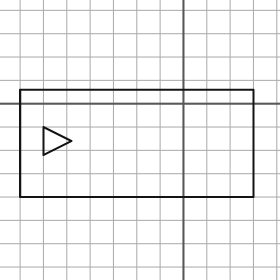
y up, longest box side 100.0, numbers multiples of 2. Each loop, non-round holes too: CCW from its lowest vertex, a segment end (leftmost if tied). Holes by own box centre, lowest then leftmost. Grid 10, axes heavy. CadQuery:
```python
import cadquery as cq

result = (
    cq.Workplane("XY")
    .moveTo(-70.0, -40.0)
    .lineTo(30.0, -40.0)
    .lineTo(30.0, 6.0)
    .lineTo(-70.0, 6.0)
    .close()
    .moveTo(-60.0, -22.0)
    .lineTo(-48.0, -16.0)
    .lineTo(-60.0, -10.0)
    .close()
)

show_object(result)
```